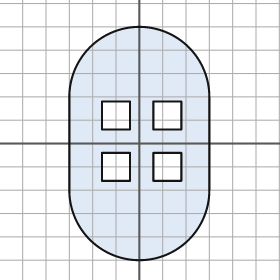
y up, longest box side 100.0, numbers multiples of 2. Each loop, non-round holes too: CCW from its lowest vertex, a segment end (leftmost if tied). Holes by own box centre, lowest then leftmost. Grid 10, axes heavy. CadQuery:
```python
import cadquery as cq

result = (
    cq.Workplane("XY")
    .moveTo(-30.0, -20.0)
    .threePointArc((0.0, -50.0), (30.0, -20.0))
    .lineTo(30.0, 20.0)
    .threePointArc((0.0, 50.0), (-30.0, 20.0))
    .close()
    .moveTo(-16.0, -16.0)
    .lineTo(-4.0, -16.0)
    .lineTo(-4.0, -4.0)
    .lineTo(-16.0, -4.0)
    .close()
    .moveTo(6.0, -16.0)
    .lineTo(18.0, -16.0)
    .lineTo(18.0, -4.0)
    .lineTo(6.0, -4.0)
    .close()
    .moveTo(-16.0, 6.0)
    .lineTo(-4.0, 6.0)
    .lineTo(-4.0, 18.0)
    .lineTo(-16.0, 18.0)
    .close()
    .moveTo(6.0, 6.0)
    .lineTo(18.0, 6.0)
    .lineTo(18.0, 18.0)
    .lineTo(6.0, 18.0)
    .close()
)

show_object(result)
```